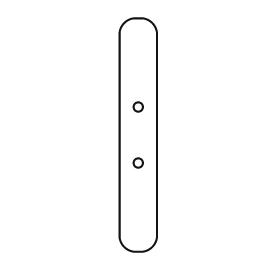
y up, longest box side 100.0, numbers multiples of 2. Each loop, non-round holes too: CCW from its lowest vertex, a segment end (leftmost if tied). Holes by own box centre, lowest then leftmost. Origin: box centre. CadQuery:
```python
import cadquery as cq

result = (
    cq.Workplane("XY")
    .moveTo(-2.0, -50.0)
    .lineTo(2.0, -50.0)
    .threePointArc((6.0, -48.0), (8.0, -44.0))
    .lineTo(8.0, 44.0)
    .threePointArc((6.0, 48.0), (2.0, 50.0))
    .lineTo(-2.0, 50.0)
    .threePointArc((-6.0, 48.0), (-8.0, 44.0))
    .lineTo(-8.0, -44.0)
    .threePointArc((-6.0, -48.0), (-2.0, -50.0))
    .close()
    .moveTo(0.0, -12.0)
    .circle(2.0)
    .moveTo(0.0, 12.0)
    .circle(2.0)
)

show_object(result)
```